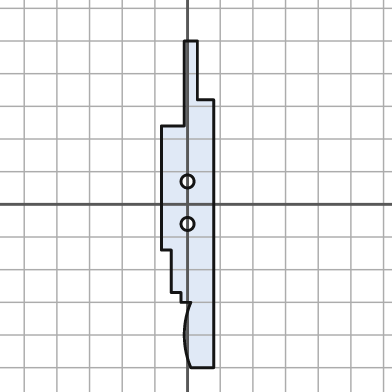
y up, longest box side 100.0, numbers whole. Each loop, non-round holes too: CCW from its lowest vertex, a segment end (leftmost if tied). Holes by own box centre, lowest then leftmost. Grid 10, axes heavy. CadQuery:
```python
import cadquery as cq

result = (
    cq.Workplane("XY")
    .moveTo(1.0, -50.0)
    .lineTo(8.0, -50.0)
    .lineTo(8.0, 32.0)
    .lineTo(3.0, 32.0)
    .lineTo(3.0, 50.0)
    .lineTo(-1.0, 50.0)
    .lineTo(-1.0, 24.0)
    .lineTo(-8.0, 24.0)
    .lineTo(-8.0, -14.0)
    .lineTo(-5.0, -14.0)
    .lineTo(-5.0, -27.0)
    .lineTo(-2.0, -27.0)
    .lineTo(-2.0, -30.0)
    .lineTo(1.0, -30.0)
    .threePointArc((-1.0, -40.0), (1.0, -50.0))
    .close()
    .moveTo(0.0, -6.0)
    .circle(2.0)
    .moveTo(0.0, 7.0)
    .circle(2.0)
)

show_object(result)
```